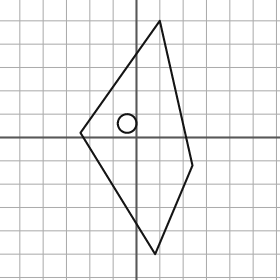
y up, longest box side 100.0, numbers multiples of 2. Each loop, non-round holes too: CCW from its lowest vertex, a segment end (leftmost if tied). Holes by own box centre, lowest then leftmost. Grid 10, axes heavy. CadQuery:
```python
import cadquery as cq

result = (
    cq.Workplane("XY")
    .moveTo(8.0, -50.0)
    .lineTo(24.0, -12.0)
    .lineTo(10.0, 50.0)
    .lineTo(-24.0, 2.0)
    .close()
    .moveTo(-4.0, 6.0)
    .circle(4.0)
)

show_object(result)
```